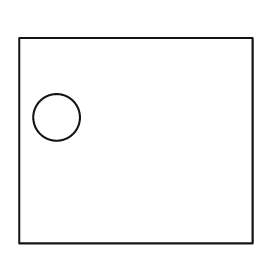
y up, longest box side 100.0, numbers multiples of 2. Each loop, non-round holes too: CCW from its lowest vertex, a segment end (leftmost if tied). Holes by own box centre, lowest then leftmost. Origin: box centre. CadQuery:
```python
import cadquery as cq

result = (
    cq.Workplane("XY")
    .moveTo(-50.0, -44.0)
    .lineTo(50.0, -44.0)
    .lineTo(50.0, 44.0)
    .lineTo(-50.0, 44.0)
    .close()
    .moveTo(-34.0, 10.0)
    .circle(10.0)
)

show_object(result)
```